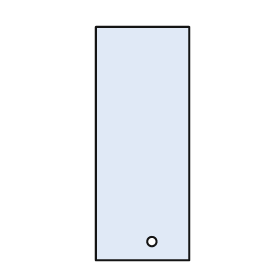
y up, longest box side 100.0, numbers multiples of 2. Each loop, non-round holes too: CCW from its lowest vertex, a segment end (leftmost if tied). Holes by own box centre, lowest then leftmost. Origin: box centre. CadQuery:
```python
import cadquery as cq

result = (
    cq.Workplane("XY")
    .moveTo(-20.0, -50.0)
    .lineTo(20.0, -50.0)
    .lineTo(20.0, 50.0)
    .lineTo(-20.0, 50.0)
    .close()
    .moveTo(4.0, -42.0)
    .circle(2.0)
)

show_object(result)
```